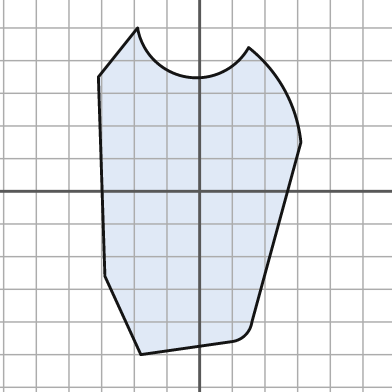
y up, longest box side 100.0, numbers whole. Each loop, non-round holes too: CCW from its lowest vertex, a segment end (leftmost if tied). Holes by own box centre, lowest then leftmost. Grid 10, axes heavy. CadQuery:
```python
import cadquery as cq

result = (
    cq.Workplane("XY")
    .moveTo(-18.0, -50.0)
    .lineTo(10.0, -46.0)
    .threePointArc((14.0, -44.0), (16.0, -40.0))
    .lineTo(31.0, 15.0)
    .threePointArc((26.0, 31.0), (15.0, 44.0))
    .threePointArc((-4.0, 35.0), (-19.0, 50.0))
    .lineTo(-31.0, 35.0)
    .lineTo(-29.0, -26.0)
    .close()
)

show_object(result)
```